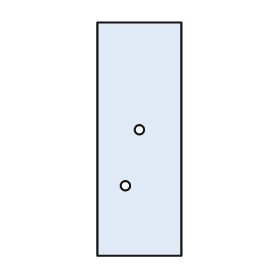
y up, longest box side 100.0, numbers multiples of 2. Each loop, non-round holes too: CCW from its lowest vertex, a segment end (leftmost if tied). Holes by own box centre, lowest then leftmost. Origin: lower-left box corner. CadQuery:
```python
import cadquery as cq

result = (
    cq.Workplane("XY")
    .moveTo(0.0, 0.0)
    .lineTo(36.0, 0.0)
    .lineTo(36.0, 100.0)
    .lineTo(0.0, 100.0)
    .close()
    .moveTo(12.0, 30.0)
    .circle(2.0)
    .moveTo(18.0, 54.0)
    .circle(2.0)
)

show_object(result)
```